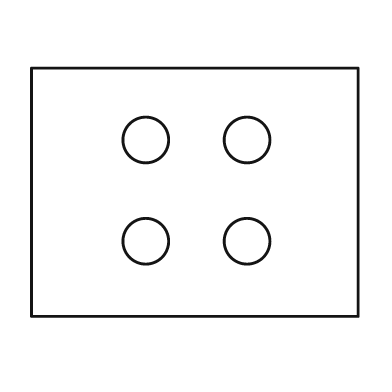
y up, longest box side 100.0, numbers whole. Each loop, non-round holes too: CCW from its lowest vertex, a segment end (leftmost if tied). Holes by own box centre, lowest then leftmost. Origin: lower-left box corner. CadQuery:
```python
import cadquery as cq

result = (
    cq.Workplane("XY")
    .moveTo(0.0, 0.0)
    .lineTo(100.0, 0.0)
    .lineTo(100.0, 76.0)
    .lineTo(0.0, 76.0)
    .close()
    .moveTo(35.0, 23.0)
    .circle(7.0)
    .moveTo(66.0, 23.0)
    .circle(7.0)
    .moveTo(35.0, 54.0)
    .circle(7.0)
    .moveTo(66.0, 54.0)
    .circle(7.0)
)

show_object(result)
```